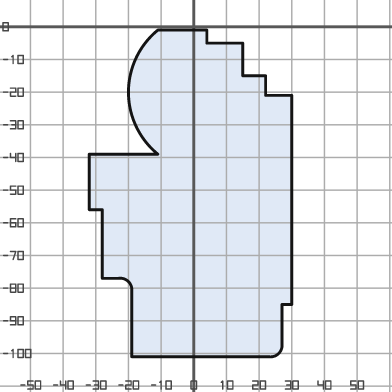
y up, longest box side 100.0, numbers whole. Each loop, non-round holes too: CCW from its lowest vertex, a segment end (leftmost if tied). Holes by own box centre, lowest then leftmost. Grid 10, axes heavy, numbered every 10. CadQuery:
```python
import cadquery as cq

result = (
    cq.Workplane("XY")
    .moveTo(-19.0, -101.0)
    .lineTo(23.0, -101.0)
    .threePointArc((26.0, -100.0), (27.0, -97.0))
    .lineTo(27.0, -85.0)
    .lineTo(30.0, -85.0)
    .lineTo(30.0, -21.0)
    .lineTo(22.0, -21.0)
    .lineTo(22.0, -15.0)
    .lineTo(15.0, -15.0)
    .lineTo(15.0, -5.0)
    .lineTo(4.0, -5.0)
    .lineTo(4.0, -1.0)
    .lineTo(-11.0, -1.0)
    .threePointArc((-20.0, -20.0), (-11.0, -39.0))
    .lineTo(-32.0, -39.0)
    .lineTo(-32.0, -56.0)
    .lineTo(-28.0, -56.0)
    .lineTo(-28.0, -77.0)
    .lineTo(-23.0, -77.0)
    .threePointArc((-20.0, -78.0), (-19.0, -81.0))
    .close()
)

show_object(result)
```